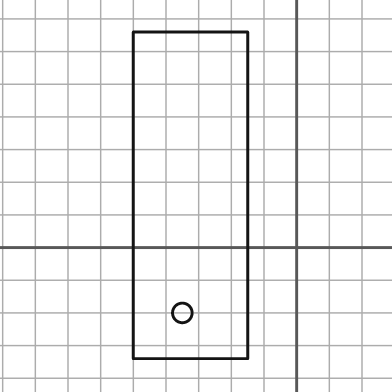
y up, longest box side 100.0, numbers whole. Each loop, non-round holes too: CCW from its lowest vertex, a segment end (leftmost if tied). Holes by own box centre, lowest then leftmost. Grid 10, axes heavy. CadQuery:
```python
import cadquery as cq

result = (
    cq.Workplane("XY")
    .moveTo(-50.0, -34.0)
    .lineTo(-15.0, -34.0)
    .lineTo(-15.0, 66.0)
    .lineTo(-50.0, 66.0)
    .close()
    .moveTo(-35.0, -20.0)
    .circle(3.0)
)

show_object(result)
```